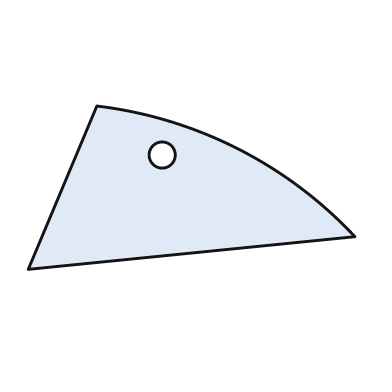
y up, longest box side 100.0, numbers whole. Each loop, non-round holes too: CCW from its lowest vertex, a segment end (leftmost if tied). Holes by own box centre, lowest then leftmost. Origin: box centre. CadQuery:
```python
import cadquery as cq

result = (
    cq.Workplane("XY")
    .moveTo(-50.0, -25.0)
    .lineTo(50.0, -15.0)
    .threePointArc((14.0, 12.0), (-29.0, 25.0))
    .close()
    .moveTo(-9.0, 10.0)
    .circle(4.0)
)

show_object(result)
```